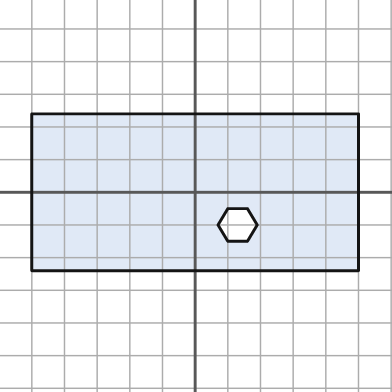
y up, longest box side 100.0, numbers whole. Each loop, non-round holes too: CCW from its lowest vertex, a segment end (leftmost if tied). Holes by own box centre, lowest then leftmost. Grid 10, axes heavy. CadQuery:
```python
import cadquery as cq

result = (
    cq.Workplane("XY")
    .moveTo(-50.0, -24.0)
    .lineTo(50.0, -24.0)
    .lineTo(50.0, 24.0)
    .lineTo(-50.0, 24.0)
    .close()
    .moveTo(10.0, -15.0)
    .lineTo(16.0, -15.0)
    .lineTo(19.0, -10.0)
    .lineTo(16.0, -5.0)
    .lineTo(10.0, -5.0)
    .lineTo(7.0, -10.0)
    .close()
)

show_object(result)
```